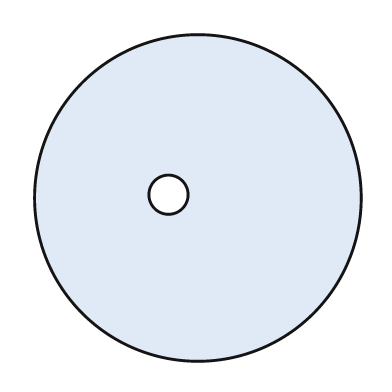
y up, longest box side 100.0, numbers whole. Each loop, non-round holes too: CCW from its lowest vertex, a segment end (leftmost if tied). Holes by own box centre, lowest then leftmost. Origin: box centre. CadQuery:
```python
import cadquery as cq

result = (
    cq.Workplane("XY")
    .moveTo(0.0, 0.0)
    .circle(50.0)
    .moveTo(-9.0, 1.0)
    .circle(6.0)
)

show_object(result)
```